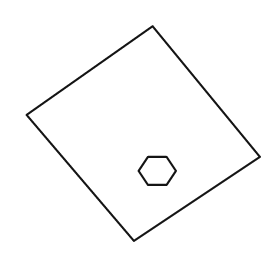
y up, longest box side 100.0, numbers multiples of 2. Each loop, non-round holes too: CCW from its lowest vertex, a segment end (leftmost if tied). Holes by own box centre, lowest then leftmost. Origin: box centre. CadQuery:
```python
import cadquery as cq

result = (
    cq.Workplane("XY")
    .moveTo(-4.0, -46.0)
    .lineTo(50.0, -10.0)
    .lineTo(4.0, 46.0)
    .lineTo(-50.0, 8.0)
    .close()
    .moveTo(2.0, -22.0)
    .lineTo(10.0, -22.0)
    .lineTo(14.0, -16.0)
    .lineTo(10.0, -10.0)
    .lineTo(2.0, -10.0)
    .lineTo(-2.0, -16.0)
    .close()
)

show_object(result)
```